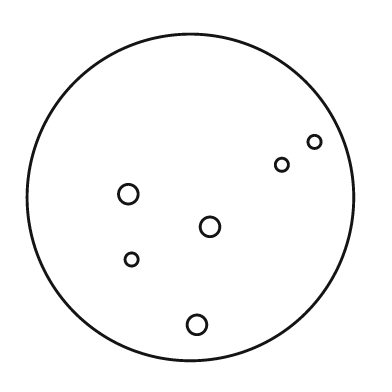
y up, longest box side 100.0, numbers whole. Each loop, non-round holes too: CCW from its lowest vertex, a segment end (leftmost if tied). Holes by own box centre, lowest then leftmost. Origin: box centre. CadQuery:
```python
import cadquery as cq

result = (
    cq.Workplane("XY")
    .moveTo(0.0, 0.0)
    .circle(50.0)
    .moveTo(2.0, -39.0)
    .circle(3.0)
    .moveTo(-18.0, -19.0)
    .circle(2.0)
    .moveTo(6.0, -9.0)
    .circle(3.0)
    .moveTo(-19.0, 1.0)
    .circle(3.0)
    .moveTo(28.0, 10.0)
    .circle(2.0)
    .moveTo(38.0, 17.0)
    .circle(2.0)
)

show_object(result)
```